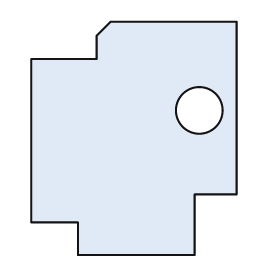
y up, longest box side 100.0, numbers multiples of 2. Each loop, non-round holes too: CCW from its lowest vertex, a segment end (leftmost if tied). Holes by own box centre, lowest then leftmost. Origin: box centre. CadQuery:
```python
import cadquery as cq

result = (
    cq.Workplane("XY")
    .moveTo(-24.0, -50.0)
    .lineTo(26.0, -50.0)
    .lineTo(26.0, -24.0)
    .lineTo(44.0, -24.0)
    .lineTo(44.0, 50.0)
    .lineTo(-10.0, 50.0)
    .lineTo(-16.0, 44.0)
    .lineTo(-16.0, 34.0)
    .lineTo(-44.0, 34.0)
    .lineTo(-44.0, -36.0)
    .lineTo(-24.0, -36.0)
    .close()
    .moveTo(28.0, 12.0)
    .circle(10.0)
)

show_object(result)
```